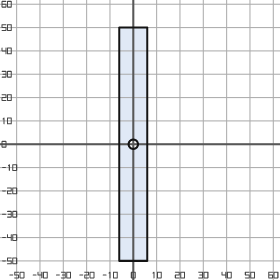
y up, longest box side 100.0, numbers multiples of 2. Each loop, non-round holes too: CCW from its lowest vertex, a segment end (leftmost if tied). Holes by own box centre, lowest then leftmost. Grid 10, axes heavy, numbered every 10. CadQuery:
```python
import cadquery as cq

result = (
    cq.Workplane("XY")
    .moveTo(-6.0, -50.0)
    .lineTo(6.0, -50.0)
    .lineTo(6.0, 50.0)
    .lineTo(-6.0, 50.0)
    .close()
    .moveTo(0.0, 0.0)
    .circle(2.0)
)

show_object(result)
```